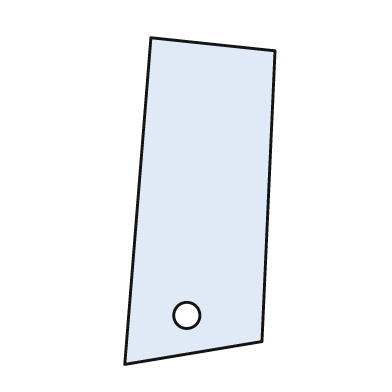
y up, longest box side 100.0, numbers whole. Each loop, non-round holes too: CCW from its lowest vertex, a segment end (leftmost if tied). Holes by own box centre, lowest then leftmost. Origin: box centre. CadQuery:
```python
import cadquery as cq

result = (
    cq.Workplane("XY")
    .moveTo(-23.0, -50.0)
    .lineTo(19.0, -43.0)
    .lineTo(23.0, 46.0)
    .lineTo(-15.0, 50.0)
    .close()
    .moveTo(-4.0, -35.0)
    .circle(4.0)
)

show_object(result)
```